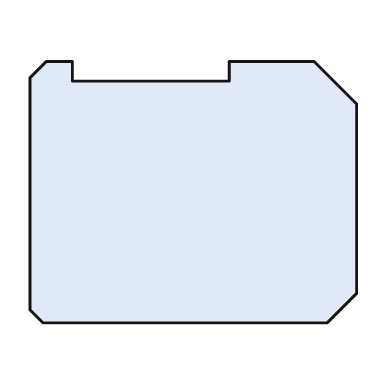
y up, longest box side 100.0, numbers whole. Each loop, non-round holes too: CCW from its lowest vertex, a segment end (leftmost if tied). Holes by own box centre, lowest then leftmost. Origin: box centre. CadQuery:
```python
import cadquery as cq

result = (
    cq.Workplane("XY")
    .moveTo(-46.0, -40.0)
    .lineTo(41.0, -40.0)
    .lineTo(50.0, -31.0)
    .lineTo(50.0, 27.0)
    .lineTo(37.0, 40.0)
    .lineTo(11.0, 40.0)
    .lineTo(11.0, 34.0)
    .lineTo(-37.0, 34.0)
    .lineTo(-37.0, 40.0)
    .lineTo(-45.0, 40.0)
    .lineTo(-50.0, 35.0)
    .lineTo(-50.0, -36.0)
    .close()
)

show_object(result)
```